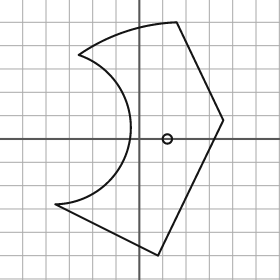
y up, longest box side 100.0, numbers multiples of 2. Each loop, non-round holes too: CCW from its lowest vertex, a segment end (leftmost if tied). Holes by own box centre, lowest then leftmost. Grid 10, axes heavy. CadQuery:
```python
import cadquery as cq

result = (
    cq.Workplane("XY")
    .moveTo(8.0, -50.0)
    .lineTo(36.0, 8.0)
    .lineTo(16.0, 50.0)
    .threePointArc((-6.0, 46.0), (-26.0, 36.0))
    .threePointArc((-4.0, 0.0), (-36.0, -28.0))
    .close()
    .moveTo(12.0, 0.0)
    .circle(2.0)
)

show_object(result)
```